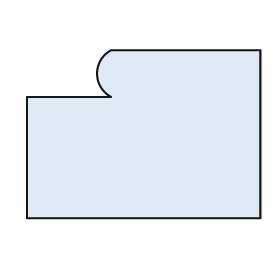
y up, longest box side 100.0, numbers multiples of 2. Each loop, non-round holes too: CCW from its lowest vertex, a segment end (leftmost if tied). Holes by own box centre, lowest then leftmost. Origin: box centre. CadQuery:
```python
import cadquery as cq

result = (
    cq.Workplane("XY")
    .moveTo(-50.0, -36.0)
    .lineTo(50.0, -36.0)
    .lineTo(50.0, 36.0)
    .lineTo(-14.0, 36.0)
    .threePointArc((-20.0, 26.0), (-14.0, 16.0))
    .lineTo(-50.0, 16.0)
    .close()
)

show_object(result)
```